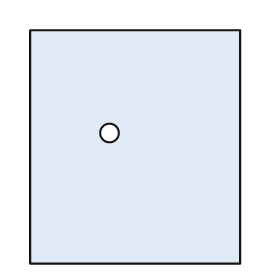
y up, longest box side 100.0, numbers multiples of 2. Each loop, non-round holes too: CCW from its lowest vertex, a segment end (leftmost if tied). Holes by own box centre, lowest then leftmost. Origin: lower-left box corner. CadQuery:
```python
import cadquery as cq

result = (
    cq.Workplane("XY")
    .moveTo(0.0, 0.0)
    .lineTo(90.0, 0.0)
    .lineTo(90.0, 100.0)
    .lineTo(0.0, 100.0)
    .close()
    .moveTo(34.0, 56.0)
    .circle(4.0)
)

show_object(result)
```